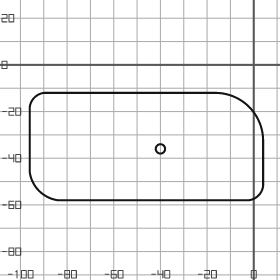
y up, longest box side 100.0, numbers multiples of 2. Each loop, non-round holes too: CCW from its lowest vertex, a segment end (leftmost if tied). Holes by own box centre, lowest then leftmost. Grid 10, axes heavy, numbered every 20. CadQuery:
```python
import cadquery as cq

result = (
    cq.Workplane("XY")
    .moveTo(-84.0, -58.0)
    .lineTo(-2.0, -58.0)
    .threePointArc((2.0, -56.0), (4.0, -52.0))
    .lineTo(4.0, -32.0)
    .threePointArc((-2.0, -18.0), (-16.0, -12.0))
    .lineTo(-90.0, -12.0)
    .threePointArc((-94.0, -14.0), (-96.0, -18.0))
    .lineTo(-96.0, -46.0)
    .threePointArc((-92.0, -54.0), (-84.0, -58.0))
    .close()
    .moveTo(-40.0, -36.0)
    .circle(2.0)
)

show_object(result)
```